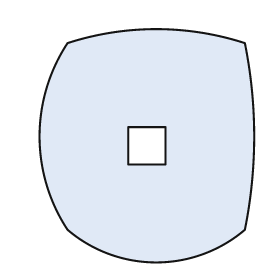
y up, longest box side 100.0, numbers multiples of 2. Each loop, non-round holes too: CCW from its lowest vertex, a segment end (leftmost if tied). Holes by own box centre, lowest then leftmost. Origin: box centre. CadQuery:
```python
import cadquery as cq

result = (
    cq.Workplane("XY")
    .moveTo(-34.0, -36.0)
    .threePointArc((4.0, -50.0), (42.0, -36.0))
    .threePointArc((46.0, 4.0), (42.0, 44.0))
    .threePointArc((4.0, 50.0), (-34.0, 44.0))
    .threePointArc((-46.0, 4.0), (-34.0, -36.0))
    .close()
    .moveTo(-8.0, -8.0)
    .lineTo(8.0, -8.0)
    .lineTo(8.0, 8.0)
    .lineTo(-8.0, 8.0)
    .close()
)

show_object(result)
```